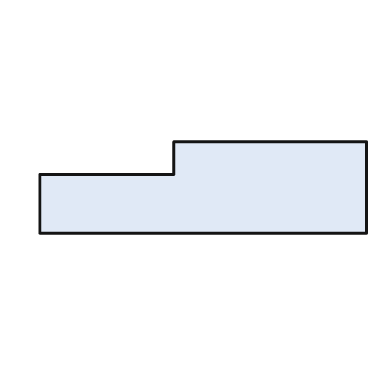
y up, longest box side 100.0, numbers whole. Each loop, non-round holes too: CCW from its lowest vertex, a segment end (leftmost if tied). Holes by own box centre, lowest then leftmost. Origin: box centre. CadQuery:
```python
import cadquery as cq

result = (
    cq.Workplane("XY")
    .moveTo(-50.0, -14.0)
    .lineTo(50.0, -14.0)
    .lineTo(50.0, 14.0)
    .lineTo(-9.0, 14.0)
    .lineTo(-9.0, 4.0)
    .lineTo(-50.0, 4.0)
    .close()
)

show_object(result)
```